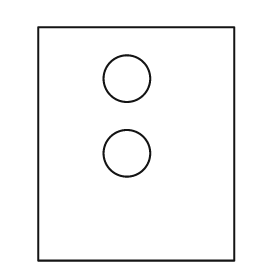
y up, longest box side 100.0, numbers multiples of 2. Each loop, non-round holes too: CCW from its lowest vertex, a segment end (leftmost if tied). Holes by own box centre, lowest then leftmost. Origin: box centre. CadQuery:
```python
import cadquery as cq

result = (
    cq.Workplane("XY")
    .moveTo(-42.0, -50.0)
    .lineTo(42.0, -50.0)
    .lineTo(42.0, 50.0)
    .lineTo(-42.0, 50.0)
    .close()
    .moveTo(-4.0, -4.0)
    .circle(10.0)
    .moveTo(-4.0, 28.0)
    .circle(10.0)
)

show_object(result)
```